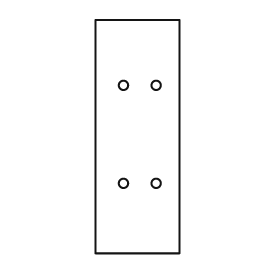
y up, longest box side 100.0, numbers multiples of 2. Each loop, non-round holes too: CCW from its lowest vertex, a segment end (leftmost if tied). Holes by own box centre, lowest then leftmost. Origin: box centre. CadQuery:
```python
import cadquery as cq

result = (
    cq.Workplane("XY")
    .moveTo(-18.0, -50.0)
    .lineTo(18.0, -50.0)
    .lineTo(18.0, 50.0)
    .lineTo(-18.0, 50.0)
    .close()
    .moveTo(-6.0, -20.0)
    .circle(2.0)
    .moveTo(8.0, -20.0)
    .circle(2.0)
    .moveTo(-6.0, 22.0)
    .circle(2.0)
    .moveTo(8.0, 22.0)
    .circle(2.0)
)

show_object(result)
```